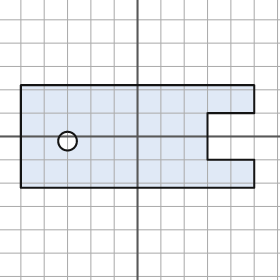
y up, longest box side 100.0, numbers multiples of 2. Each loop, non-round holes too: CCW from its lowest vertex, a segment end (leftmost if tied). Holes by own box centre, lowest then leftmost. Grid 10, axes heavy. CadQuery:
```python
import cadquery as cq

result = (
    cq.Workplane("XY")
    .moveTo(-50.0, -22.0)
    .lineTo(50.0, -22.0)
    .lineTo(50.0, -10.0)
    .lineTo(30.0, -10.0)
    .lineTo(30.0, 10.0)
    .lineTo(50.0, 10.0)
    .lineTo(50.0, 22.0)
    .lineTo(-50.0, 22.0)
    .close()
    .moveTo(-30.0, -2.0)
    .circle(4.0)
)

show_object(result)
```